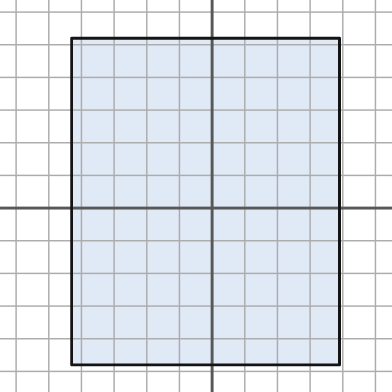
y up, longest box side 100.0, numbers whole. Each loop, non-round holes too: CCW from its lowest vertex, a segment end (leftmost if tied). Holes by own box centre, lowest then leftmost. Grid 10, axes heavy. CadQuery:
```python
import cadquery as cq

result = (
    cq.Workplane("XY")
    .moveTo(-43.0, -48.0)
    .lineTo(39.0, -48.0)
    .lineTo(39.0, 52.0)
    .lineTo(-43.0, 52.0)
    .close()
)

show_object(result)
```